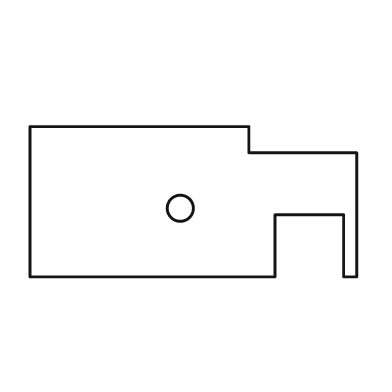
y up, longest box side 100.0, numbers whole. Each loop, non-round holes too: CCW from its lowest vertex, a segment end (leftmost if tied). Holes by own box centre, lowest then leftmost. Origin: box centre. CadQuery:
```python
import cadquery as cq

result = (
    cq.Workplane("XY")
    .moveTo(-50.0, -23.0)
    .lineTo(25.0, -23.0)
    .lineTo(25.0, -4.0)
    .lineTo(46.0, -4.0)
    .lineTo(46.0, -23.0)
    .lineTo(50.0, -23.0)
    .lineTo(50.0, 15.0)
    .lineTo(17.0, 15.0)
    .lineTo(17.0, 23.0)
    .lineTo(-50.0, 23.0)
    .close()
    .moveTo(-4.0, -2.0)
    .circle(4.0)
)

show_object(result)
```